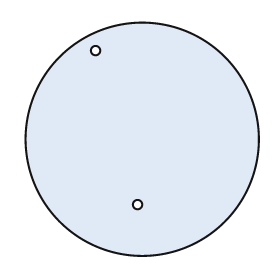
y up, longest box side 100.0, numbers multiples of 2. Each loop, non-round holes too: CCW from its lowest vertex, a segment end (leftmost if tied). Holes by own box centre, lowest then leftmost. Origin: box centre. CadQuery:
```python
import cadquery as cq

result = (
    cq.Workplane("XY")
    .moveTo(0.0, 0.0)
    .circle(50.0)
    .moveTo(-2.0, -28.0)
    .circle(2.0)
    .moveTo(-20.0, 38.0)
    .circle(2.0)
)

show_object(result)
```